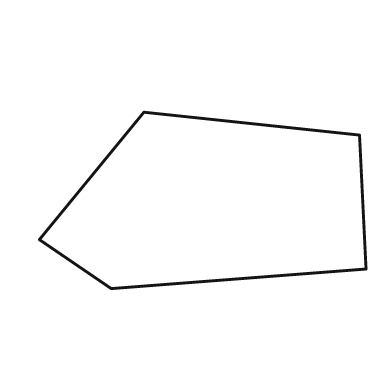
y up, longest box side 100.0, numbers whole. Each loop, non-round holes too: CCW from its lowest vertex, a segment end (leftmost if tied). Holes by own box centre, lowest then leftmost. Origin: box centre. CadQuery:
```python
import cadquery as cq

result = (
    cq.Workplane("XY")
    .moveTo(-28.0, -27.0)
    .lineTo(50.0, -21.0)
    .lineTo(48.0, 20.0)
    .lineTo(-18.0, 27.0)
    .lineTo(-50.0, -12.0)
    .close()
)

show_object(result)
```